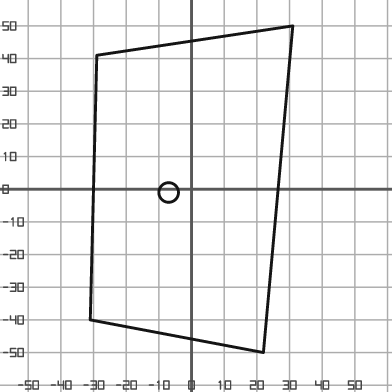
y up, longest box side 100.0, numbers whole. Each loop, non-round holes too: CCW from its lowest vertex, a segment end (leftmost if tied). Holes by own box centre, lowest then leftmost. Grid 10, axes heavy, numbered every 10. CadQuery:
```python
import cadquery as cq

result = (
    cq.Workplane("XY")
    .moveTo(22.0, -50.0)
    .lineTo(31.0, 50.0)
    .lineTo(-29.0, 41.0)
    .lineTo(-31.0, -40.0)
    .close()
    .moveTo(-7.0, -1.0)
    .circle(3.0)
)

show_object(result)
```